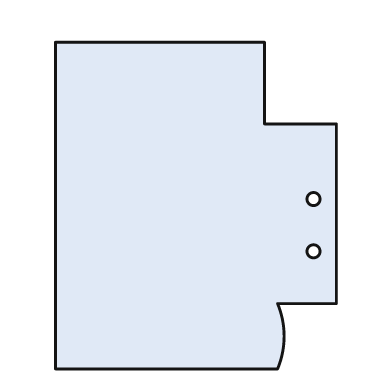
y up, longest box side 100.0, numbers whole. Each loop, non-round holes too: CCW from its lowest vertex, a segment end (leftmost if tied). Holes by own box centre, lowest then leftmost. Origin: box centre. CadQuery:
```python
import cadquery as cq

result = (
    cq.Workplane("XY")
    .moveTo(-43.0, -50.0)
    .lineTo(25.0, -50.0)
    .threePointArc((27.0, -40.0), (25.0, -30.0))
    .lineTo(43.0, -30.0)
    .lineTo(43.0, 25.0)
    .lineTo(21.0, 25.0)
    .lineTo(21.0, 50.0)
    .lineTo(-43.0, 50.0)
    .close()
    .moveTo(36.0, -14.0)
    .circle(2.0)
    .moveTo(36.0, 2.0)
    .circle(2.0)
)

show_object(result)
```